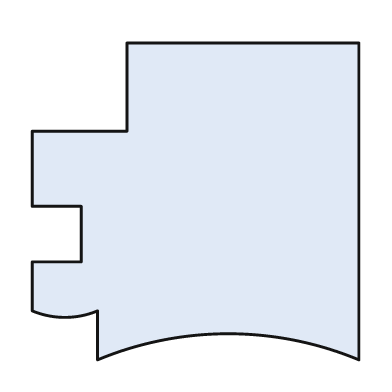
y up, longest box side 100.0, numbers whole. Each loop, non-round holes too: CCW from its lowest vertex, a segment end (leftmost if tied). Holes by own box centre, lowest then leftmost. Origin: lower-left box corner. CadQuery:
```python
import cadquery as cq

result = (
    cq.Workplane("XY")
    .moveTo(20.0, 0.0)
    .threePointArc((60.0, 8.0), (100.0, 0.0))
    .lineTo(100.0, 97.0)
    .lineTo(29.0, 97.0)
    .lineTo(29.0, 70.0)
    .lineTo(0.0, 70.0)
    .lineTo(0.0, 47.0)
    .lineTo(15.0, 47.0)
    .lineTo(15.0, 30.0)
    .lineTo(0.0, 30.0)
    .lineTo(0.0, 15.0)
    .threePointArc((10.0, 13.0), (20.0, 15.0))
    .close()
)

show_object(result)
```